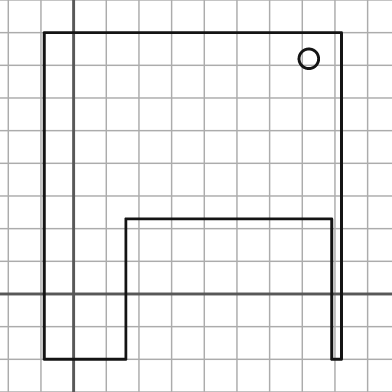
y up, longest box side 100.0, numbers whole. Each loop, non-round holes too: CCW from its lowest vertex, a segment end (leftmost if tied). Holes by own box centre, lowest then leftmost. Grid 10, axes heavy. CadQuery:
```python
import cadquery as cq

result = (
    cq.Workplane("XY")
    .moveTo(-9.0, -20.0)
    .lineTo(16.0, -20.0)
    .lineTo(16.0, 23.0)
    .lineTo(79.0, 23.0)
    .lineTo(79.0, -20.0)
    .lineTo(82.0, -20.0)
    .lineTo(82.0, 80.0)
    .lineTo(-9.0, 80.0)
    .close()
    .moveTo(72.0, 72.0)
    .circle(3.0)
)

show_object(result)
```